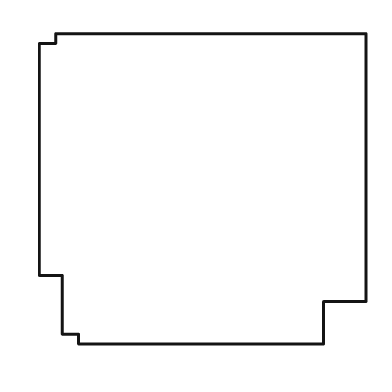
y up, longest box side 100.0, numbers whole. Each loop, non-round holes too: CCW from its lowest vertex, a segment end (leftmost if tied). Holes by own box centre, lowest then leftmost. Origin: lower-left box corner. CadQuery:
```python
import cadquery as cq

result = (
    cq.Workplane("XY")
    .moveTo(12.0, 0.0)
    .lineTo(87.0, 0.0)
    .lineTo(87.0, 13.0)
    .lineTo(100.0, 13.0)
    .lineTo(100.0, 95.0)
    .lineTo(5.0, 95.0)
    .lineTo(5.0, 92.0)
    .lineTo(0.0, 92.0)
    .lineTo(0.0, 21.0)
    .lineTo(7.0, 21.0)
    .lineTo(7.0, 3.0)
    .lineTo(12.0, 3.0)
    .close()
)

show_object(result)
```